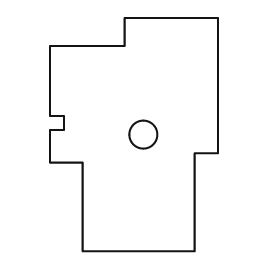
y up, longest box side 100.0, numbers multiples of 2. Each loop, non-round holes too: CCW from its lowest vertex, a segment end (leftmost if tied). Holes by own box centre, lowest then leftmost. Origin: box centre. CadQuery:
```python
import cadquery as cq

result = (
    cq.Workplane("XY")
    .moveTo(-22.0, -50.0)
    .lineTo(26.0, -50.0)
    .lineTo(26.0, -8.0)
    .lineTo(36.0, -8.0)
    .lineTo(36.0, 50.0)
    .lineTo(-4.0, 50.0)
    .lineTo(-4.0, 38.0)
    .lineTo(-36.0, 38.0)
    .lineTo(-36.0, 8.0)
    .lineTo(-30.0, 8.0)
    .lineTo(-30.0, 2.0)
    .lineTo(-36.0, 2.0)
    .lineTo(-36.0, -12.0)
    .lineTo(-22.0, -12.0)
    .close()
    .moveTo(4.0, 0.0)
    .circle(6.0)
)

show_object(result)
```